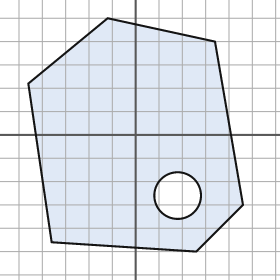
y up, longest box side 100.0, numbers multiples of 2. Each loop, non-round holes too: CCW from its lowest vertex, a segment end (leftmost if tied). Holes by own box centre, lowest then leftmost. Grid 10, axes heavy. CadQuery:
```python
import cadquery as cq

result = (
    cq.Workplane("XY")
    .moveTo(26.0, -50.0)
    .lineTo(46.0, -30.0)
    .lineTo(34.0, 40.0)
    .lineTo(-12.0, 50.0)
    .lineTo(-46.0, 22.0)
    .lineTo(-36.0, -46.0)
    .close()
    .moveTo(18.0, -26.0)
    .circle(10.0)
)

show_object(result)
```